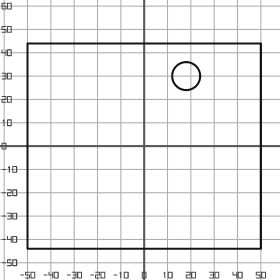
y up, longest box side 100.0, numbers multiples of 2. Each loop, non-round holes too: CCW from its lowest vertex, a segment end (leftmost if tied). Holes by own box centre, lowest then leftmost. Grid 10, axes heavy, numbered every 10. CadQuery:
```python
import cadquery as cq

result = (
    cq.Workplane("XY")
    .moveTo(-50.0, -44.0)
    .lineTo(50.0, -44.0)
    .lineTo(50.0, 44.0)
    .lineTo(-50.0, 44.0)
    .close()
    .moveTo(18.0, 30.0)
    .circle(6.0)
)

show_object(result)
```